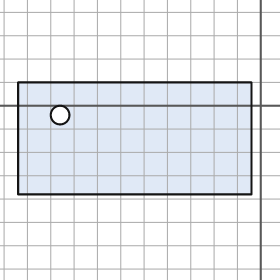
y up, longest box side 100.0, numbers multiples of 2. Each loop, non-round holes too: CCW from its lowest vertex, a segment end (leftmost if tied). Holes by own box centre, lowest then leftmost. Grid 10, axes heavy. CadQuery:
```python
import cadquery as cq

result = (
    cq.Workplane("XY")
    .moveTo(-104.0, -38.0)
    .lineTo(-4.0, -38.0)
    .lineTo(-4.0, 10.0)
    .lineTo(-104.0, 10.0)
    .close()
    .moveTo(-86.0, -4.0)
    .circle(4.0)
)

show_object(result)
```